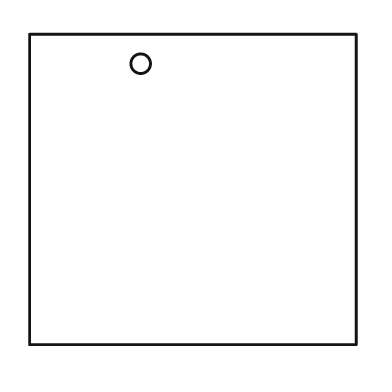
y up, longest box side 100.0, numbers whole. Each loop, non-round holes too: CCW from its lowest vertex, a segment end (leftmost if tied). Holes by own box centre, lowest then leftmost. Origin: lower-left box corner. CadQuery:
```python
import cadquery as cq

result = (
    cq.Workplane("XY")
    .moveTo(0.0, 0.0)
    .lineTo(100.0, 0.0)
    .lineTo(100.0, 95.0)
    .lineTo(0.0, 95.0)
    .close()
    .moveTo(34.0, 86.0)
    .circle(3.0)
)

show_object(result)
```